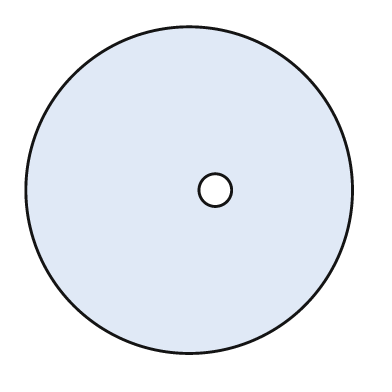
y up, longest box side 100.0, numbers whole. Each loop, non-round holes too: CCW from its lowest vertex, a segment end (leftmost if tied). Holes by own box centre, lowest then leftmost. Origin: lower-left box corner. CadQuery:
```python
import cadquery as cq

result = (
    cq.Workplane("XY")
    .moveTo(50.0, 50.0)
    .circle(50.0)
    .moveTo(58.0, 50.0)
    .circle(5.0)
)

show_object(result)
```